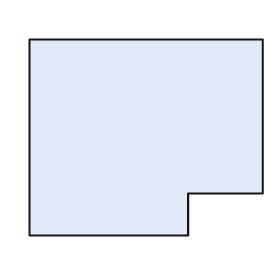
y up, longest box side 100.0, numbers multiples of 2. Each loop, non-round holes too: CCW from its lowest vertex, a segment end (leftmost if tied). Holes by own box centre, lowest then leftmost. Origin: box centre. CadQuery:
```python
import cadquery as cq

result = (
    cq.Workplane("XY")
    .moveTo(-50.0, -42.0)
    .lineTo(18.0, -42.0)
    .lineTo(18.0, -24.0)
    .lineTo(50.0, -24.0)
    .lineTo(50.0, 42.0)
    .lineTo(-50.0, 42.0)
    .close()
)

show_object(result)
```